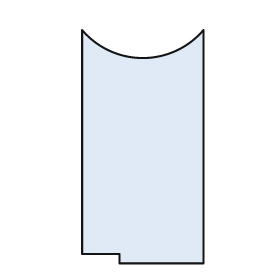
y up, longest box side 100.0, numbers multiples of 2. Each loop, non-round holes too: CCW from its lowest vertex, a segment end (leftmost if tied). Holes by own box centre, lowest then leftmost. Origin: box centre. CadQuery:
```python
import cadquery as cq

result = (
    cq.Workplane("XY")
    .moveTo(-10.0, -50.0)
    .lineTo(26.0, -50.0)
    .lineTo(26.0, 50.0)
    .threePointArc((0.0, 38.0), (-26.0, 50.0))
    .lineTo(-26.0, -46.0)
    .lineTo(-10.0, -46.0)
    .close()
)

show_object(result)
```